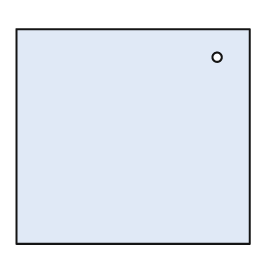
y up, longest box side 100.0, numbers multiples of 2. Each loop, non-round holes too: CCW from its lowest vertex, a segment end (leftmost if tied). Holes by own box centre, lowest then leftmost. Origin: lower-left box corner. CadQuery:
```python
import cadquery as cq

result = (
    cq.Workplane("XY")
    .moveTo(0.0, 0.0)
    .lineTo(100.0, 0.0)
    .lineTo(100.0, 92.0)
    .lineTo(0.0, 92.0)
    .close()
    .moveTo(86.0, 80.0)
    .circle(2.0)
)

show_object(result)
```